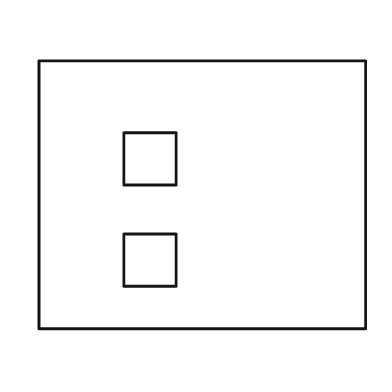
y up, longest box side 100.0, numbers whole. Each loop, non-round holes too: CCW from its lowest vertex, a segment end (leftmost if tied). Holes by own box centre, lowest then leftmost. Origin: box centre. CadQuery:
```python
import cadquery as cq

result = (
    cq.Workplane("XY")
    .moveTo(-50.0, -41.0)
    .lineTo(50.0, -41.0)
    .lineTo(50.0, 41.0)
    .lineTo(-50.0, 41.0)
    .close()
    .moveTo(-24.0, -28.0)
    .lineTo(-8.0, -28.0)
    .lineTo(-8.0, -12.0)
    .lineTo(-24.0, -12.0)
    .close()
    .moveTo(-24.0, 3.0)
    .lineTo(-8.0, 3.0)
    .lineTo(-8.0, 19.0)
    .lineTo(-24.0, 19.0)
    .close()
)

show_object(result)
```